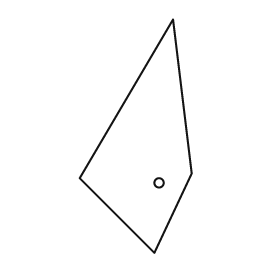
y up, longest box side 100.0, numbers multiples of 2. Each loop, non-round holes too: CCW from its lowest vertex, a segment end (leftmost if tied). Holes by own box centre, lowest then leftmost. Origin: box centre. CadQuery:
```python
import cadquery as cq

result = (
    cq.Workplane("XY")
    .moveTo(8.0, -50.0)
    .lineTo(24.0, -16.0)
    .lineTo(16.0, 50.0)
    .lineTo(-24.0, -18.0)
    .close()
    .moveTo(10.0, -20.0)
    .circle(2.0)
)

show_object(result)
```